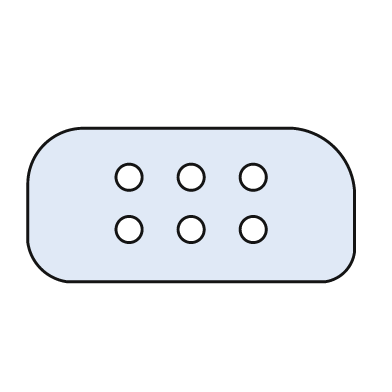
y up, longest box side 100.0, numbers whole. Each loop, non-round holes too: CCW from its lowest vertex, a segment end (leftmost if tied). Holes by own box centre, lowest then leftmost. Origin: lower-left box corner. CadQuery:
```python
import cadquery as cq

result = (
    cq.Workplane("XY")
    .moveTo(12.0, 0.0)
    .lineTo(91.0, 0.0)
    .threePointArc((97.0, 3.0), (100.0, 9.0))
    .lineTo(100.0, 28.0)
    .threePointArc((94.0, 41.0), (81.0, 47.0))
    .lineTo(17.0, 47.0)
    .threePointArc((5.0, 42.0), (0.0, 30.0))
    .lineTo(0.0, 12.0)
    .threePointArc((4.0, 4.0), (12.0, 0.0))
    .close()
    .moveTo(31.0, 16.0)
    .circle(4.0)
    .moveTo(50.0, 16.0)
    .circle(4.0)
    .moveTo(69.0, 16.0)
    .circle(4.0)
    .moveTo(31.0, 32.0)
    .circle(4.0)
    .moveTo(50.0, 32.0)
    .circle(4.0)
    .moveTo(69.0, 32.0)
    .circle(4.0)
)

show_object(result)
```